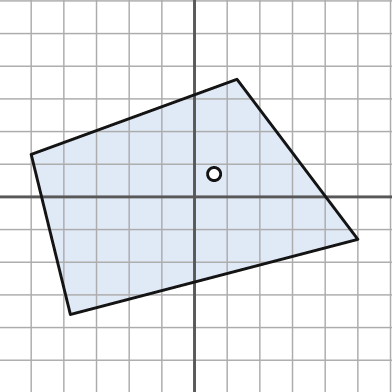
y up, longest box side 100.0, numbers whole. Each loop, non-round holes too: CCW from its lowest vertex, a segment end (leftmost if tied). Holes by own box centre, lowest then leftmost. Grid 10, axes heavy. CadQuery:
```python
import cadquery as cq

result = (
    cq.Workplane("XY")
    .moveTo(-38.0, -36.0)
    .lineTo(50.0, -13.0)
    .lineTo(13.0, 36.0)
    .lineTo(-50.0, 13.0)
    .close()
    .moveTo(6.0, 7.0)
    .circle(2.0)
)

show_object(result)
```